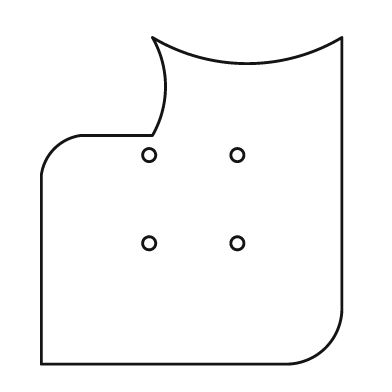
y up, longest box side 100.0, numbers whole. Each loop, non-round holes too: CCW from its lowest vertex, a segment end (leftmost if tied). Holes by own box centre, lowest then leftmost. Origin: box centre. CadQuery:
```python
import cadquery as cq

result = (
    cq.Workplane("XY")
    .moveTo(-46.0, -50.0)
    .lineTo(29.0, -50.0)
    .threePointArc((41.0, -45.0), (46.0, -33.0))
    .lineTo(46.0, 50.0)
    .threePointArc((17.0, 42.0), (-12.0, 50.0))
    .threePointArc((-8.0, 35.0), (-12.0, 20.0))
    .lineTo(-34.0, 20.0)
    .threePointArc((-42.0, 16.0), (-46.0, 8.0))
    .close()
    .moveTo(-13.0, -13.0)
    .circle(2.0)
    .moveTo(14.0, -13.0)
    .circle(2.0)
    .moveTo(-13.0, 14.0)
    .circle(2.0)
    .moveTo(14.0, 14.0)
    .circle(2.0)
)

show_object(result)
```